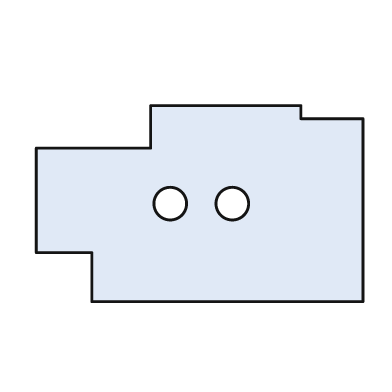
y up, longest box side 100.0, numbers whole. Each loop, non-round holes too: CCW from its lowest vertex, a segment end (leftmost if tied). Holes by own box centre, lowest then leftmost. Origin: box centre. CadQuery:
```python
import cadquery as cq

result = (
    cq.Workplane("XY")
    .moveTo(-33.0, -30.0)
    .lineTo(50.0, -30.0)
    .lineTo(50.0, 26.0)
    .lineTo(31.0, 26.0)
    .lineTo(31.0, 30.0)
    .lineTo(-15.0, 30.0)
    .lineTo(-15.0, 17.0)
    .lineTo(-50.0, 17.0)
    .lineTo(-50.0, -15.0)
    .lineTo(-33.0, -15.0)
    .close()
    .moveTo(-9.0, 0.0)
    .circle(5.0)
    .moveTo(10.0, 0.0)
    .circle(5.0)
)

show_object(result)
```